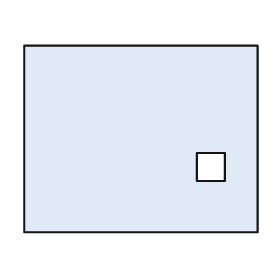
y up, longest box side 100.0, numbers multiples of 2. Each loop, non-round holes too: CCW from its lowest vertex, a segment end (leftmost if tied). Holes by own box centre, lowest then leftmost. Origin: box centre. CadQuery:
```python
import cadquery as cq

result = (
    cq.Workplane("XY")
    .moveTo(-50.0, -40.0)
    .lineTo(50.0, -40.0)
    .lineTo(50.0, 40.0)
    .lineTo(-50.0, 40.0)
    .close()
    .moveTo(24.0, -18.0)
    .lineTo(36.0, -18.0)
    .lineTo(36.0, -6.0)
    .lineTo(24.0, -6.0)
    .close()
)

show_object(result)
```